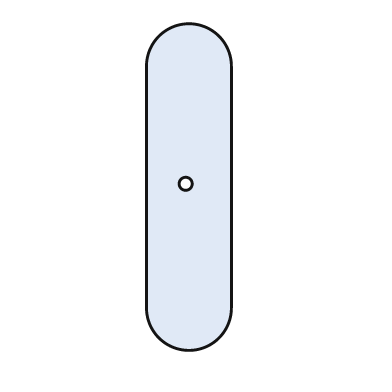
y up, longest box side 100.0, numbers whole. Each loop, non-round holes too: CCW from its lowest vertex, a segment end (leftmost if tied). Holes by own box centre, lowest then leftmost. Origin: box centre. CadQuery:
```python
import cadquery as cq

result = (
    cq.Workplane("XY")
    .moveTo(-13.0, -37.0)
    .threePointArc((0.0, -50.0), (13.0, -37.0))
    .lineTo(13.0, 37.0)
    .threePointArc((0.0, 50.0), (-13.0, 37.0))
    .close()
    .moveTo(-1.0, 1.0)
    .circle(2.0)
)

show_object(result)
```